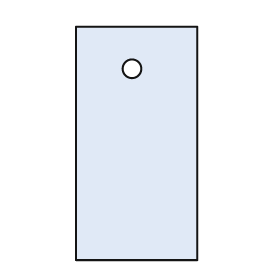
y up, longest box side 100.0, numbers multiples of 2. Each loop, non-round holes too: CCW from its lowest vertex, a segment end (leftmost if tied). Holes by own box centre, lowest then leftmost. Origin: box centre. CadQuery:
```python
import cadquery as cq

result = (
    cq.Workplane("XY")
    .moveTo(-26.0, -50.0)
    .lineTo(26.0, -50.0)
    .lineTo(26.0, 50.0)
    .lineTo(-26.0, 50.0)
    .close()
    .moveTo(-2.0, 32.0)
    .circle(4.0)
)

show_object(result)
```